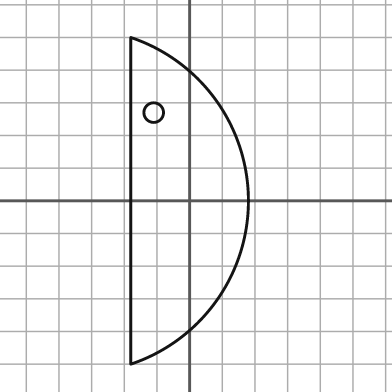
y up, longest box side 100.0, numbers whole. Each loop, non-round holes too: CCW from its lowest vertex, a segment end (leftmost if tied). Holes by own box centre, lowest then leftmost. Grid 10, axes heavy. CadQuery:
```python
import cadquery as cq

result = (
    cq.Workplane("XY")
    .moveTo(-18.0, -50.0)
    .threePointArc((18.0, 0.0), (-18.0, 50.0))
    .close()
    .moveTo(-11.0, 27.0)
    .circle(3.0)
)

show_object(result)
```